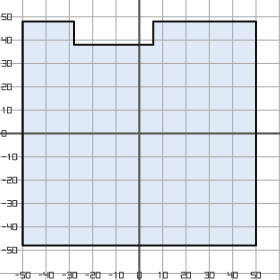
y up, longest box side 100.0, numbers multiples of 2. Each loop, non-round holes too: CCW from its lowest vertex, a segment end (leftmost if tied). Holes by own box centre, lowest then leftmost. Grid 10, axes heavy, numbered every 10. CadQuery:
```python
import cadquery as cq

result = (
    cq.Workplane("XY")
    .moveTo(-50.0, -48.0)
    .lineTo(50.0, -48.0)
    .lineTo(50.0, 48.0)
    .lineTo(6.0, 48.0)
    .lineTo(6.0, 38.0)
    .lineTo(-28.0, 38.0)
    .lineTo(-28.0, 48.0)
    .lineTo(-50.0, 48.0)
    .close()
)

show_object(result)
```